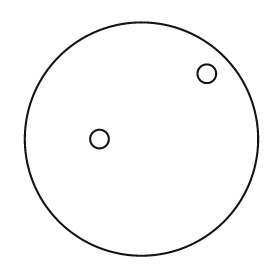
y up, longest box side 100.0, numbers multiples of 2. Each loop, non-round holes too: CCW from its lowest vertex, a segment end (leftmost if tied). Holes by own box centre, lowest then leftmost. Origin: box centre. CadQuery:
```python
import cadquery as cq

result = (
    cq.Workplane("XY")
    .moveTo(0.0, 0.0)
    .circle(50.0)
    .moveTo(-18.0, 0.0)
    .circle(4.0)
    .moveTo(28.0, 28.0)
    .circle(4.0)
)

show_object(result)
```